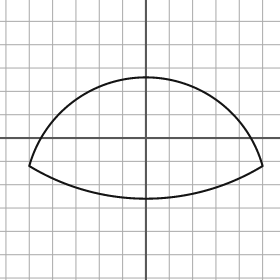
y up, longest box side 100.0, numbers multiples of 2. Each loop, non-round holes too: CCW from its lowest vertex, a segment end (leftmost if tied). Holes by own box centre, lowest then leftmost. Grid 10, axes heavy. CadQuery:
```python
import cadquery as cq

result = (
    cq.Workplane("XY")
    .moveTo(-50.0, -12.0)
    .threePointArc((0.0, -26.0), (50.0, -12.0))
    .threePointArc((0.0, 26.0), (-50.0, -12.0))
    .close()
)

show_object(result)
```